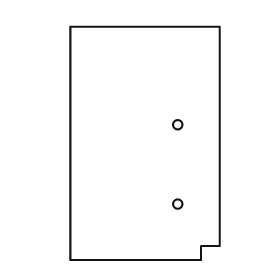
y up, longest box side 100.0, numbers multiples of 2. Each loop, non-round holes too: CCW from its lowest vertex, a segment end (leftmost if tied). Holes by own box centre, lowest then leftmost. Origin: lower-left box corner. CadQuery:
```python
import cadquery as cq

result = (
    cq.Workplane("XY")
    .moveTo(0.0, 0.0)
    .lineTo(56.0, 0.0)
    .lineTo(56.0, 6.0)
    .lineTo(64.0, 6.0)
    .lineTo(64.0, 100.0)
    .lineTo(0.0, 100.0)
    .close()
    .moveTo(46.0, 24.0)
    .circle(2.0)
    .moveTo(46.0, 58.0)
    .circle(2.0)
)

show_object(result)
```